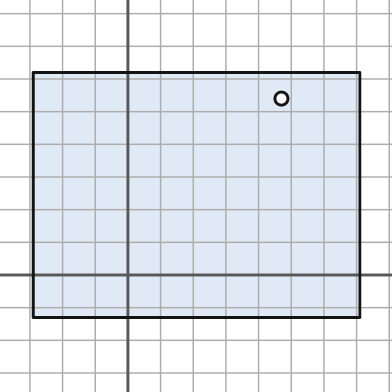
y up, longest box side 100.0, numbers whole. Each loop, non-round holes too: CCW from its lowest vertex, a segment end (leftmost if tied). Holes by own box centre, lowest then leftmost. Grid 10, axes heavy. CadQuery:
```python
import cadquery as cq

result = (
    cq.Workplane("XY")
    .moveTo(-29.0, -13.0)
    .lineTo(71.0, -13.0)
    .lineTo(71.0, 62.0)
    .lineTo(-29.0, 62.0)
    .close()
    .moveTo(47.0, 54.0)
    .circle(2.0)
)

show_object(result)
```